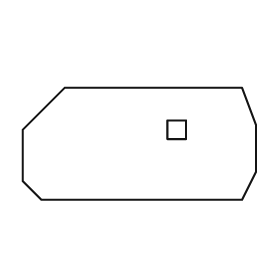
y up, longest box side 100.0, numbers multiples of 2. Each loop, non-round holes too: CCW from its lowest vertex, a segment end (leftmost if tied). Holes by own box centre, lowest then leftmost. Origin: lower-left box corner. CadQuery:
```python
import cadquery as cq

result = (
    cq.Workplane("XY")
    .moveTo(8.0, 0.0)
    .lineTo(94.0, 0.0)
    .lineTo(100.0, 12.0)
    .lineTo(100.0, 32.0)
    .lineTo(94.0, 48.0)
    .lineTo(18.0, 48.0)
    .lineTo(0.0, 30.0)
    .lineTo(0.0, 8.0)
    .close()
    .moveTo(62.0, 26.0)
    .lineTo(70.0, 26.0)
    .lineTo(70.0, 34.0)
    .lineTo(62.0, 34.0)
    .close()
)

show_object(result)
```